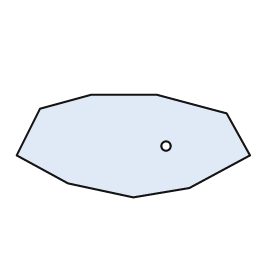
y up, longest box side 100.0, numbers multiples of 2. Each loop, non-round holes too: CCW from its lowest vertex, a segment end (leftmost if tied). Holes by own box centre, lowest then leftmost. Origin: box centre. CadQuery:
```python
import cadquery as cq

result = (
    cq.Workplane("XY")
    .moveTo(0.0, -22.0)
    .lineTo(24.0, -18.0)
    .lineTo(50.0, -4.0)
    .lineTo(40.0, 14.0)
    .lineTo(10.0, 22.0)
    .lineTo(-18.0, 22.0)
    .lineTo(-40.0, 16.0)
    .lineTo(-50.0, -4.0)
    .lineTo(-28.0, -16.0)
    .close()
    .moveTo(14.0, 0.0)
    .circle(2.0)
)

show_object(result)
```